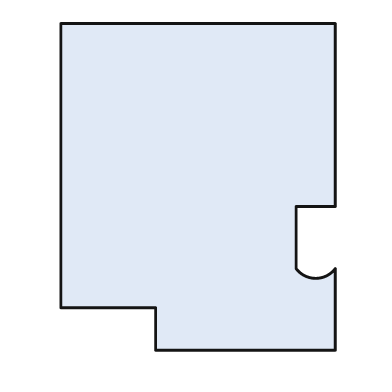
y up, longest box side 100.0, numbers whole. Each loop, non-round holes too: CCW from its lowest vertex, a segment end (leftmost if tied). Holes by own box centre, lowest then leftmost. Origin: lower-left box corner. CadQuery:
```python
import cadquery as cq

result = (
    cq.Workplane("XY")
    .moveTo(29.0, 0.0)
    .lineTo(84.0, 0.0)
    .lineTo(84.0, 25.0)
    .threePointArc((78.0, 22.0), (72.0, 25.0))
    .lineTo(72.0, 44.0)
    .lineTo(84.0, 44.0)
    .lineTo(84.0, 100.0)
    .lineTo(0.0, 100.0)
    .lineTo(0.0, 13.0)
    .lineTo(29.0, 13.0)
    .close()
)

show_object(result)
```